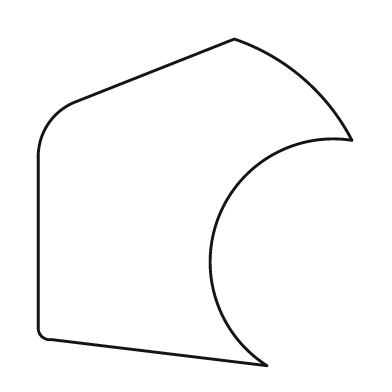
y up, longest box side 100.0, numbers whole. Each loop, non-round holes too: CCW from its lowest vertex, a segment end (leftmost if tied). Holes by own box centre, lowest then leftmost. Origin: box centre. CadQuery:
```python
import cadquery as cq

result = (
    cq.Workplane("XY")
    .moveTo(22.0, -50.0)
    .threePointArc((7.0, -5.0), (48.0, 19.0))
    .threePointArc((33.0, 38.0), (12.0, 50.0))
    .lineTo(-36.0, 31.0)
    .threePointArc((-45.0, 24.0), (-48.0, 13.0))
    .lineTo(-48.0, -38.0)
    .threePointArc((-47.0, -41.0), (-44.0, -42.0))
    .close()
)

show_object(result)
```